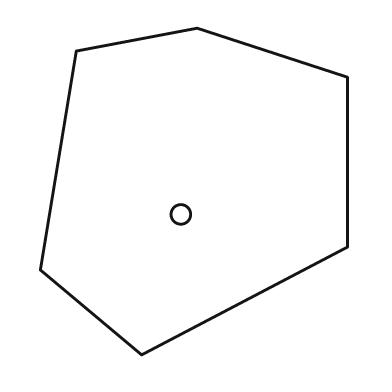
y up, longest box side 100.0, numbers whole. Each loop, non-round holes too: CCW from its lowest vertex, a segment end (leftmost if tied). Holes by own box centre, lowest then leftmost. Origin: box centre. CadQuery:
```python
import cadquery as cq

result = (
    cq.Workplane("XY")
    .moveTo(-16.0, -50.0)
    .lineTo(47.0, -17.0)
    .lineTo(47.0, 35.0)
    .lineTo(1.0, 50.0)
    .lineTo(-36.0, 43.0)
    .lineTo(-47.0, -24.0)
    .close()
    .moveTo(-4.0, -7.0)
    .circle(3.0)
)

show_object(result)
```